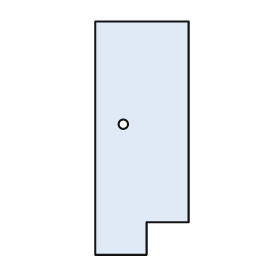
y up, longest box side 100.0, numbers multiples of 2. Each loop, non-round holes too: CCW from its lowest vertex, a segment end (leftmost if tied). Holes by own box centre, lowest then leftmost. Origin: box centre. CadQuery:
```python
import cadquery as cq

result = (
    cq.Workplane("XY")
    .moveTo(-20.0, -50.0)
    .lineTo(2.0, -50.0)
    .lineTo(2.0, -36.0)
    .lineTo(20.0, -36.0)
    .lineTo(20.0, 50.0)
    .lineTo(-20.0, 50.0)
    .close()
    .moveTo(-8.0, 6.0)
    .circle(2.0)
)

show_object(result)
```